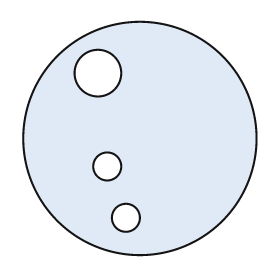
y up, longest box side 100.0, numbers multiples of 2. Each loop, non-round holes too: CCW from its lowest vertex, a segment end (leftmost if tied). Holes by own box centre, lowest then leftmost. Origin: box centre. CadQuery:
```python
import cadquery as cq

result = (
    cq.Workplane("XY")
    .moveTo(0.0, 0.0)
    .circle(50.0)
    .moveTo(-6.0, -34.0)
    .circle(6.0)
    .moveTo(-14.0, -12.0)
    .circle(6.0)
    .moveTo(-18.0, 28.0)
    .circle(10.0)
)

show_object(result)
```